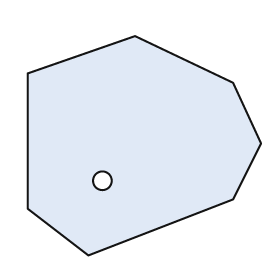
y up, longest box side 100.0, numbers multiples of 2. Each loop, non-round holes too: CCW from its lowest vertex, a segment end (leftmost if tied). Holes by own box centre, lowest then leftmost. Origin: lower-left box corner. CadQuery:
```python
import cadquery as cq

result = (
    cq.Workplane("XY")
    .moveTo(26.0, 0.0)
    .lineTo(88.0, 24.0)
    .lineTo(100.0, 48.0)
    .lineTo(88.0, 74.0)
    .lineTo(46.0, 94.0)
    .lineTo(0.0, 78.0)
    .lineTo(0.0, 20.0)
    .close()
    .moveTo(32.0, 32.0)
    .circle(4.0)
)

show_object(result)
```